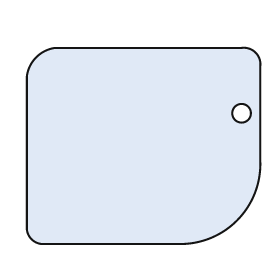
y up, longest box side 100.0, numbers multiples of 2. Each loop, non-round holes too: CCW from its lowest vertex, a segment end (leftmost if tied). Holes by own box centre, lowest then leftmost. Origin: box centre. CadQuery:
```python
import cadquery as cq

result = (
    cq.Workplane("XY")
    .moveTo(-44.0, -42.0)
    .lineTo(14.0, -42.0)
    .threePointArc((40.0, -32.0), (50.0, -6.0))
    .lineTo(50.0, 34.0)
    .threePointArc((48.0, 40.0), (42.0, 42.0))
    .lineTo(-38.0, 42.0)
    .threePointArc((-46.0, 38.0), (-50.0, 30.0))
    .lineTo(-50.0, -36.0)
    .threePointArc((-48.0, -40.0), (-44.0, -42.0))
    .close()
    .moveTo(42.0, 14.0)
    .circle(4.0)
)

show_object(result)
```